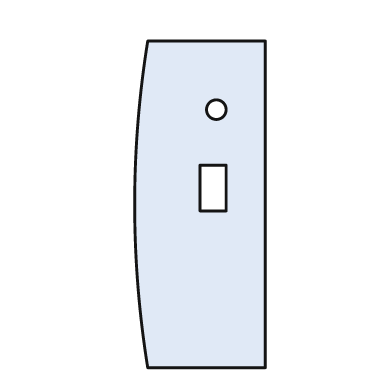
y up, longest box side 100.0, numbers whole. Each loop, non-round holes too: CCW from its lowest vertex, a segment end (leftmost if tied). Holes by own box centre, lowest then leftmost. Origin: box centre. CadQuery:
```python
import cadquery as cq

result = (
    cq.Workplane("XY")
    .moveTo(-16.0, -50.0)
    .lineTo(20.0, -50.0)
    .lineTo(20.0, 50.0)
    .lineTo(-16.0, 50.0)
    .threePointArc((-20.0, 0.0), (-16.0, -50.0))
    .close()
    .moveTo(0.0, -2.0)
    .lineTo(8.0, -2.0)
    .lineTo(8.0, 12.0)
    .lineTo(0.0, 12.0)
    .close()
    .moveTo(5.0, 29.0)
    .circle(3.0)
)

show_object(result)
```